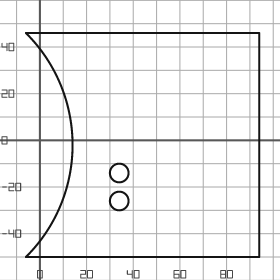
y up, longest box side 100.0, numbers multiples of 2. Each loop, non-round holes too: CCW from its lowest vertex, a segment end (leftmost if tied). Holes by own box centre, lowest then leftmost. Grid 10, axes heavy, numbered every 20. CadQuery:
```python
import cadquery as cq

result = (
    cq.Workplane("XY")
    .moveTo(-6.0, -50.0)
    .lineTo(94.0, -50.0)
    .lineTo(94.0, 46.0)
    .lineTo(-6.0, 46.0)
    .threePointArc((14.0, -2.0), (-6.0, -50.0))
    .close()
    .moveTo(34.0, -26.0)
    .circle(4.0)
    .moveTo(34.0, -14.0)
    .circle(4.0)
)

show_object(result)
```